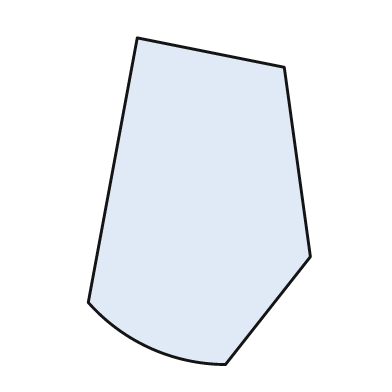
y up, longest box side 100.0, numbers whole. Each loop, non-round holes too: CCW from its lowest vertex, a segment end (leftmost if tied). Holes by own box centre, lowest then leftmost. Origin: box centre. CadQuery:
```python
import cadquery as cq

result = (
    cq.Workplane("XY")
    .moveTo(8.0, -50.0)
    .lineTo(34.0, -17.0)
    .lineTo(26.0, 41.0)
    .lineTo(-19.0, 50.0)
    .lineTo(-34.0, -31.0)
    .threePointArc((-15.0, -45.0), (8.0, -50.0))
    .close()
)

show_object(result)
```